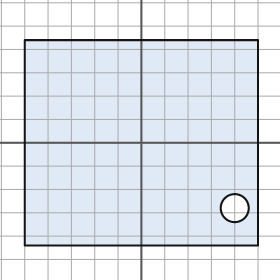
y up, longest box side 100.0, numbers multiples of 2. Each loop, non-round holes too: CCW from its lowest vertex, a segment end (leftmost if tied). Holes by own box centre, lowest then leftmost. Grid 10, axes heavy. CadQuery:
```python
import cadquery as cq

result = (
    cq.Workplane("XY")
    .moveTo(-50.0, -44.0)
    .lineTo(50.0, -44.0)
    .lineTo(50.0, 44.0)
    .lineTo(-50.0, 44.0)
    .close()
    .moveTo(40.0, -28.0)
    .circle(6.0)
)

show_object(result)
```